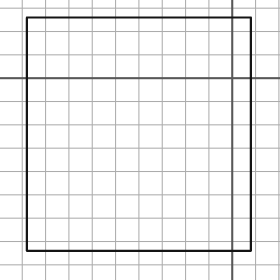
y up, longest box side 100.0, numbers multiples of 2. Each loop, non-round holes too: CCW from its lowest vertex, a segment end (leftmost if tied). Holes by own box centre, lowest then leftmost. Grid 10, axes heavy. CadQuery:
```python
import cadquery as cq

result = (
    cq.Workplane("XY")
    .moveTo(-88.0, -74.0)
    .lineTo(8.0, -74.0)
    .lineTo(8.0, 26.0)
    .lineTo(-88.0, 26.0)
    .close()
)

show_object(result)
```